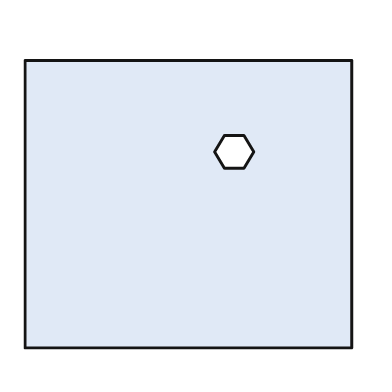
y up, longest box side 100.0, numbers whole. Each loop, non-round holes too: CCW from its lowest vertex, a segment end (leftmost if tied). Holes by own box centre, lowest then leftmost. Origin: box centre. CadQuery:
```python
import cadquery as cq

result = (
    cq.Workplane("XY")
    .moveTo(-50.0, -44.0)
    .lineTo(50.0, -44.0)
    .lineTo(50.0, 44.0)
    .lineTo(-50.0, 44.0)
    .close()
    .moveTo(11.0, 11.0)
    .lineTo(17.0, 11.0)
    .lineTo(20.0, 16.0)
    .lineTo(17.0, 21.0)
    .lineTo(11.0, 21.0)
    .lineTo(8.0, 16.0)
    .close()
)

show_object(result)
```